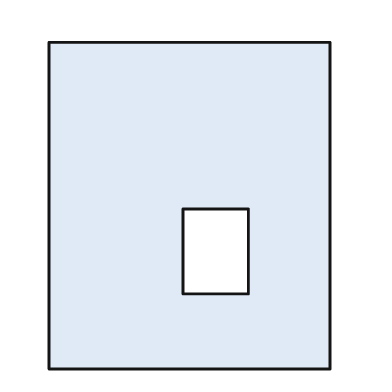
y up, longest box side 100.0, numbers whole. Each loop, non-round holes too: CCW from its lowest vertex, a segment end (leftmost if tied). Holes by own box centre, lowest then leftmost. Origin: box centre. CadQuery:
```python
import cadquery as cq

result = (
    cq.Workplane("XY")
    .moveTo(-43.0, -50.0)
    .lineTo(43.0, -50.0)
    .lineTo(43.0, 50.0)
    .lineTo(-43.0, 50.0)
    .close()
    .moveTo(-2.0, -27.0)
    .lineTo(18.0, -27.0)
    .lineTo(18.0, -1.0)
    .lineTo(-2.0, -1.0)
    .close()
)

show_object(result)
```